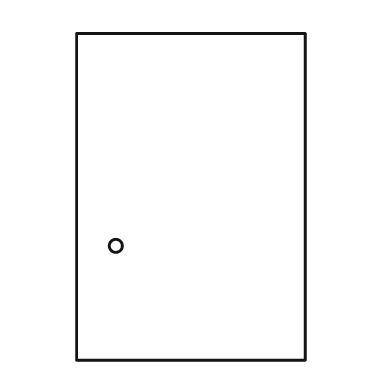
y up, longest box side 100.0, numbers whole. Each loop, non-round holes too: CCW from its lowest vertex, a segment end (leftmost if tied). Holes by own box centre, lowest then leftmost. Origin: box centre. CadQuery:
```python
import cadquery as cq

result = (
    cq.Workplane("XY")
    .moveTo(-35.0, -50.0)
    .lineTo(35.0, -50.0)
    .lineTo(35.0, 50.0)
    .lineTo(-35.0, 50.0)
    .close()
    .moveTo(-23.0, -15.0)
    .circle(2.0)
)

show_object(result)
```